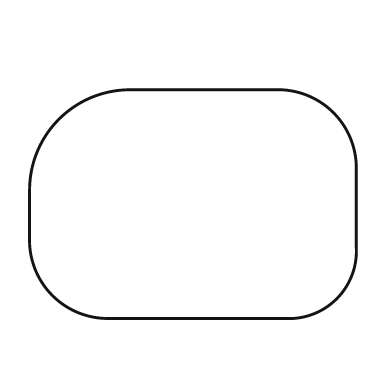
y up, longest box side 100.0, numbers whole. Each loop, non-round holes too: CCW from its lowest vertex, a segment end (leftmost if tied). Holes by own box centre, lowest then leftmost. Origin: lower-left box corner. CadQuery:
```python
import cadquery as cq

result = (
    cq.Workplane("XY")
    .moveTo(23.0, 0.0)
    .lineTo(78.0, 0.0)
    .threePointArc((94.0, 6.0), (100.0, 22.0))
    .lineTo(100.0, 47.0)
    .threePointArc((93.0, 63.0), (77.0, 70.0))
    .lineTo(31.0, 70.0)
    .threePointArc((9.0, 61.0), (0.0, 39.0))
    .lineTo(0.0, 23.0)
    .threePointArc((7.0, 7.0), (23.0, 0.0))
    .close()
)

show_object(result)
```